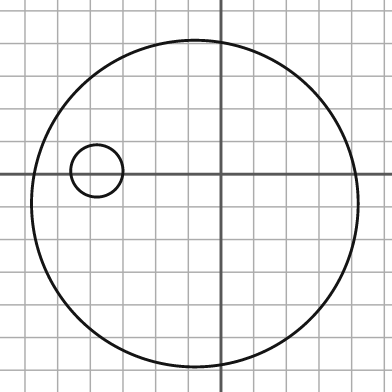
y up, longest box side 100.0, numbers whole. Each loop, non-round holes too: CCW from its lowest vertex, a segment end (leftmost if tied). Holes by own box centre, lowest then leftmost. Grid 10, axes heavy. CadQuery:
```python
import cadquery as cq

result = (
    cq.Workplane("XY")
    .moveTo(-8.0, -9.0)
    .circle(50.0)
    .moveTo(-38.0, 1.0)
    .circle(8.0)
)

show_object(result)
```